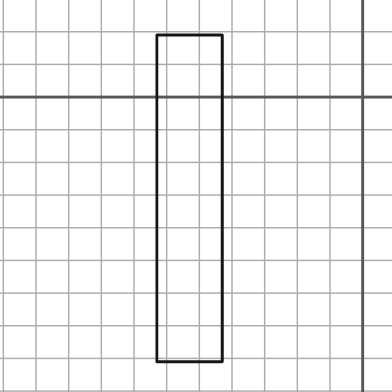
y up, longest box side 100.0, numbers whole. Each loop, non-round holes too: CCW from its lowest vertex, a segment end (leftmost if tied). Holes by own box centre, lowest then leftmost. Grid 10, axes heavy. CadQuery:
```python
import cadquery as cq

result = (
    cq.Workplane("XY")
    .moveTo(-63.0, -81.0)
    .lineTo(-43.0, -81.0)
    .lineTo(-43.0, 19.0)
    .lineTo(-63.0, 19.0)
    .close()
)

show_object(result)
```